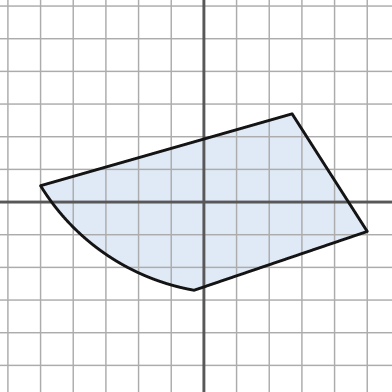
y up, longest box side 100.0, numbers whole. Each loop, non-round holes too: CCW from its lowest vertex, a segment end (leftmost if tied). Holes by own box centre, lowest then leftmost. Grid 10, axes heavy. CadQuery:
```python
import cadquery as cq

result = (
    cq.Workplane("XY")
    .moveTo(-3.0, -27.0)
    .lineTo(50.0, -9.0)
    .lineTo(27.0, 27.0)
    .lineTo(-50.0, 5.0)
    .threePointArc((-30.0, -16.0), (-3.0, -27.0))
    .close()
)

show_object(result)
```